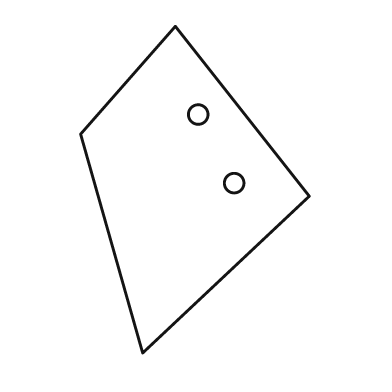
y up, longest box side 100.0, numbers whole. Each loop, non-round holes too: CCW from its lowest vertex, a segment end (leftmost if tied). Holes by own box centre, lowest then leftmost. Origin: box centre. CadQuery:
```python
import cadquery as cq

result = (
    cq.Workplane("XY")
    .moveTo(-16.0, -50.0)
    .lineTo(35.0, -2.0)
    .lineTo(-6.0, 50.0)
    .lineTo(-35.0, 17.0)
    .close()
    .moveTo(12.0, 2.0)
    .circle(3.0)
    .moveTo(1.0, 23.0)
    .circle(3.0)
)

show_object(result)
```